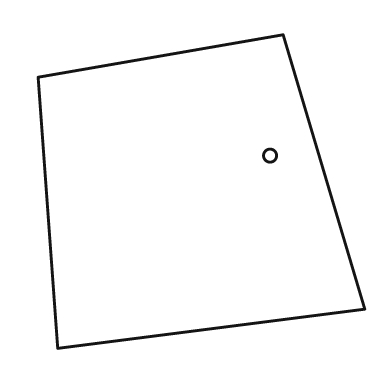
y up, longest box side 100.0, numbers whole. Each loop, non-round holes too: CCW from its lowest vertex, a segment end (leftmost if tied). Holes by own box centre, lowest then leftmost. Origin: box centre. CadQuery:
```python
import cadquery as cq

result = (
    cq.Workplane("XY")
    .moveTo(-44.0, -48.0)
    .lineTo(50.0, -36.0)
    .lineTo(25.0, 48.0)
    .lineTo(-50.0, 35.0)
    .close()
    .moveTo(21.0, 11.0)
    .circle(2.0)
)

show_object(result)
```